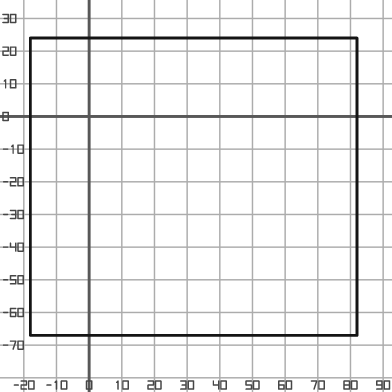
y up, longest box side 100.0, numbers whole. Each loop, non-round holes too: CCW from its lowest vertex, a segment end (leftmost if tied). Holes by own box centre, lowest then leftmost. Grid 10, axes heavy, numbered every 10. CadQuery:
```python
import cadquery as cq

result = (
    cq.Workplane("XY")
    .moveTo(-18.0, -67.0)
    .lineTo(82.0, -67.0)
    .lineTo(82.0, 24.0)
    .lineTo(-18.0, 24.0)
    .close()
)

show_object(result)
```